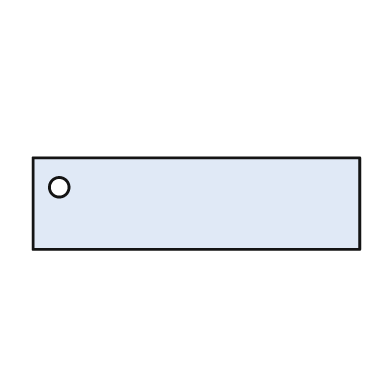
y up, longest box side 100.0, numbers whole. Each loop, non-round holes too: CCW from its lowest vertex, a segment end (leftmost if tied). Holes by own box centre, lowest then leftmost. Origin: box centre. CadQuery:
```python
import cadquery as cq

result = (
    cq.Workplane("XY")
    .moveTo(-50.0, -14.0)
    .lineTo(50.0, -14.0)
    .lineTo(50.0, 14.0)
    .lineTo(-50.0, 14.0)
    .close()
    .moveTo(-42.0, 5.0)
    .circle(3.0)
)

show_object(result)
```